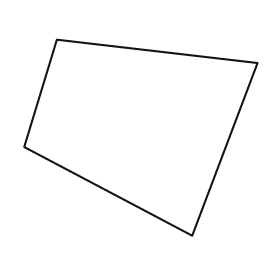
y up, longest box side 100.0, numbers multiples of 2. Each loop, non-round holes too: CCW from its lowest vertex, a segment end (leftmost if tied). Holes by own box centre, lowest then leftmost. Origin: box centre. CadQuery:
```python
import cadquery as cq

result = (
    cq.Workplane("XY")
    .moveTo(22.0, -42.0)
    .lineTo(50.0, 32.0)
    .lineTo(-36.0, 42.0)
    .lineTo(-50.0, -4.0)
    .close()
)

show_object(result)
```